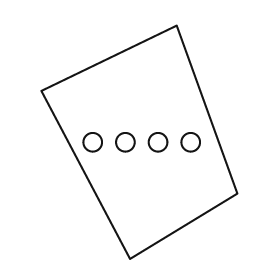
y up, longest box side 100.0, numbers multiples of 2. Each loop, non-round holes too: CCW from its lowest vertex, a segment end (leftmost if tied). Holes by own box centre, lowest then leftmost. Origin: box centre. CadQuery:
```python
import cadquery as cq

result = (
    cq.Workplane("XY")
    .moveTo(-4.0, -50.0)
    .lineTo(42.0, -22.0)
    .lineTo(16.0, 50.0)
    .lineTo(-42.0, 22.0)
    .close()
    .moveTo(-20.0, 0.0)
    .circle(4.0)
    .moveTo(-6.0, 0.0)
    .circle(4.0)
    .moveTo(8.0, 0.0)
    .circle(4.0)
    .moveTo(22.0, 0.0)
    .circle(4.0)
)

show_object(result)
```